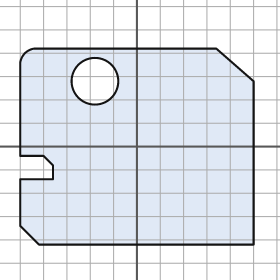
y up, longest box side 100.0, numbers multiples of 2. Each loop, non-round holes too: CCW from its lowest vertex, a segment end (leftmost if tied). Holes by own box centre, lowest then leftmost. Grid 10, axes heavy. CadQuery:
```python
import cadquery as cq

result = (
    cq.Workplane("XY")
    .moveTo(-42.0, -42.0)
    .lineTo(50.0, -42.0)
    .lineTo(50.0, 28.0)
    .lineTo(34.0, 42.0)
    .lineTo(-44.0, 42.0)
    .threePointArc((-48.0, 40.0), (-50.0, 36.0))
    .lineTo(-50.0, -4.0)
    .lineTo(-40.0, -4.0)
    .lineTo(-36.0, -8.0)
    .lineTo(-36.0, -14.0)
    .lineTo(-50.0, -14.0)
    .lineTo(-50.0, -34.0)
    .close()
    .moveTo(-18.0, 28.0)
    .circle(10.0)
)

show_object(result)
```